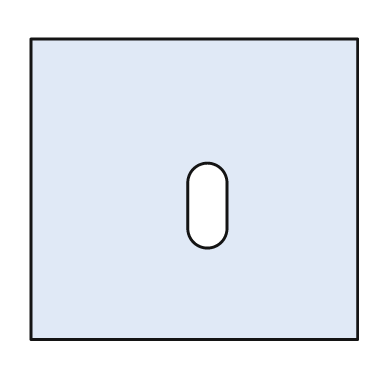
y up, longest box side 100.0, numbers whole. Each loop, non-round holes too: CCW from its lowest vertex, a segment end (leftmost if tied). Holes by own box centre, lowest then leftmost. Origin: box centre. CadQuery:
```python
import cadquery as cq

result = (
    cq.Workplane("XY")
    .moveTo(-50.0, -46.0)
    .lineTo(50.0, -46.0)
    .lineTo(50.0, 46.0)
    .lineTo(-50.0, 46.0)
    .close()
    .moveTo(-2.0, -12.0)
    .threePointArc((4.0, -18.0), (10.0, -12.0))
    .lineTo(10.0, 2.0)
    .threePointArc((4.0, 8.0), (-2.0, 2.0))
    .close()
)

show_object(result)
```